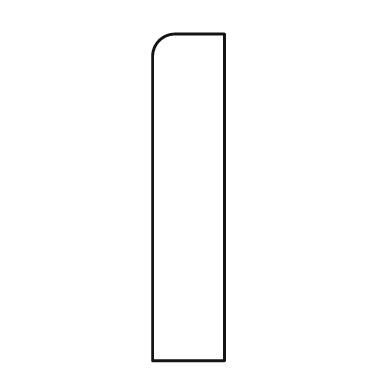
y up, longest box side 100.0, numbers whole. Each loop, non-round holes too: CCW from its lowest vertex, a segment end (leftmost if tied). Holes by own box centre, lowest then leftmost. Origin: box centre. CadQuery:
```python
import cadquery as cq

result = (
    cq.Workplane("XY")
    .moveTo(-11.0, -50.0)
    .lineTo(11.0, -50.0)
    .lineTo(11.0, 50.0)
    .lineTo(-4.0, 50.0)
    .threePointArc((-9.0, 48.0), (-11.0, 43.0))
    .close()
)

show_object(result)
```